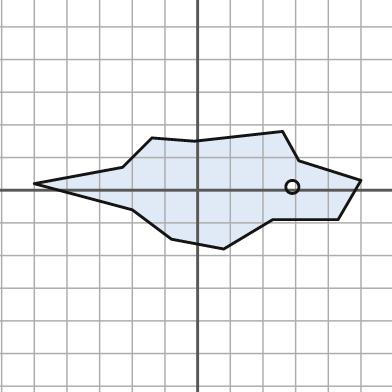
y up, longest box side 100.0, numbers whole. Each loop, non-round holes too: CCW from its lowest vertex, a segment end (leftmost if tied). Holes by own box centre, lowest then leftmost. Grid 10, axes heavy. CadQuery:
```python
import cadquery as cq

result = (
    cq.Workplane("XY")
    .moveTo(8.0, -18.0)
    .lineTo(23.0, -9.0)
    .lineTo(43.0, -9.0)
    .lineTo(50.0, 3.0)
    .lineTo(31.0, 9.0)
    .lineTo(26.0, 18.0)
    .lineTo(-1.0, 15.0)
    .lineTo(-14.0, 16.0)
    .lineTo(-23.0, 7.0)
    .lineTo(-50.0, 2.0)
    .lineTo(-20.0, -6.0)
    .lineTo(-8.0, -15.0)
    .close()
    .moveTo(29.0, 1.0)
    .circle(2.0)
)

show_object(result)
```